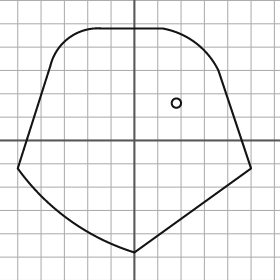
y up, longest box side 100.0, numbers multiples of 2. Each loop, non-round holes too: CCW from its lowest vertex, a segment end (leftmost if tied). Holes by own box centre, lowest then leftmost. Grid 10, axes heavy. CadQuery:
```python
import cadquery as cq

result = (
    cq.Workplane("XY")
    .moveTo(0.0, -48.0)
    .lineTo(50.0, -12.0)
    .lineTo(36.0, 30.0)
    .threePointArc((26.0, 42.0), (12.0, 48.0))
    .lineTo(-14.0, 48.0)
    .threePointArc((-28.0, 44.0), (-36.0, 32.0))
    .lineTo(-50.0, -12.0)
    .threePointArc((-28.0, -34.0), (0.0, -48.0))
    .close()
    .moveTo(18.0, 16.0)
    .circle(2.0)
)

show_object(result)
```